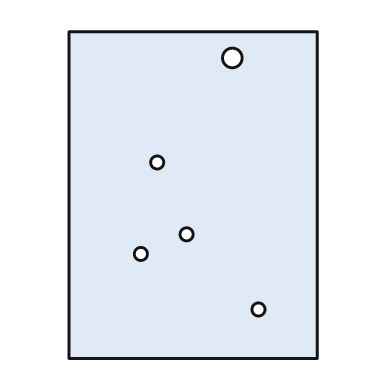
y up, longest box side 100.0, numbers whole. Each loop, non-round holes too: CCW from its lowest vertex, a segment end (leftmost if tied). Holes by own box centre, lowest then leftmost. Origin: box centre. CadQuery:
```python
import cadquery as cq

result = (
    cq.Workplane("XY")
    .moveTo(-38.0, -50.0)
    .lineTo(38.0, -50.0)
    .lineTo(38.0, 50.0)
    .lineTo(-38.0, 50.0)
    .close()
    .moveTo(20.0, -35.0)
    .circle(2.0)
    .moveTo(-16.0, -18.0)
    .circle(2.0)
    .moveTo(-2.0, -12.0)
    .circle(2.0)
    .moveTo(-11.0, 10.0)
    .circle(2.0)
    .moveTo(12.0, 42.0)
    .circle(3.0)
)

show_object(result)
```